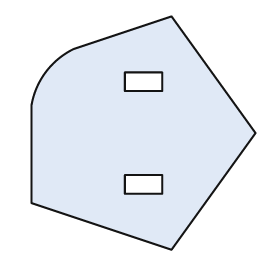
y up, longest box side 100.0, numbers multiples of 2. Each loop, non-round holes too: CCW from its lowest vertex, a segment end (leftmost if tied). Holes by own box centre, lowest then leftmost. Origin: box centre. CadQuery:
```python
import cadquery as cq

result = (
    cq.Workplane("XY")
    .moveTo(12.0, -50.0)
    .lineTo(48.0, 0.0)
    .lineTo(12.0, 50.0)
    .lineTo(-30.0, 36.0)
    .threePointArc((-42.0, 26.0), (-48.0, 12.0))
    .lineTo(-48.0, -30.0)
    .close()
    .moveTo(-8.0, -26.0)
    .lineTo(8.0, -26.0)
    .lineTo(8.0, -18.0)
    .lineTo(-8.0, -18.0)
    .close()
    .moveTo(-8.0, 18.0)
    .lineTo(8.0, 18.0)
    .lineTo(8.0, 26.0)
    .lineTo(-8.0, 26.0)
    .close()
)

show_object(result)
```